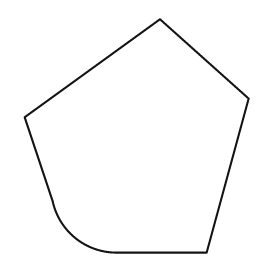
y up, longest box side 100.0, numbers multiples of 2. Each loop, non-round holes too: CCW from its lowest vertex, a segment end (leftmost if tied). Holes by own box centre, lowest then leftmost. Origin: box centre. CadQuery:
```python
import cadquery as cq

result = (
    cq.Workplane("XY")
    .moveTo(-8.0, -50.0)
    .lineTo(30.0, -50.0)
    .lineTo(48.0, 16.0)
    .lineTo(10.0, 50.0)
    .lineTo(-48.0, 8.0)
    .lineTo(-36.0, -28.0)
    .threePointArc((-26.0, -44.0), (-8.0, -50.0))
    .close()
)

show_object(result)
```